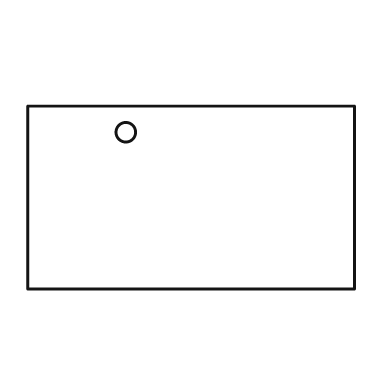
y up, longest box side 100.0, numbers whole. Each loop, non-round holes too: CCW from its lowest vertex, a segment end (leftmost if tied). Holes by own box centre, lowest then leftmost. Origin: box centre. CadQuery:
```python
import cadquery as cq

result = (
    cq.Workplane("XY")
    .moveTo(-50.0, -28.0)
    .lineTo(50.0, -28.0)
    .lineTo(50.0, 28.0)
    .lineTo(-50.0, 28.0)
    .close()
    .moveTo(-20.0, 20.0)
    .circle(3.0)
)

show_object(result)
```